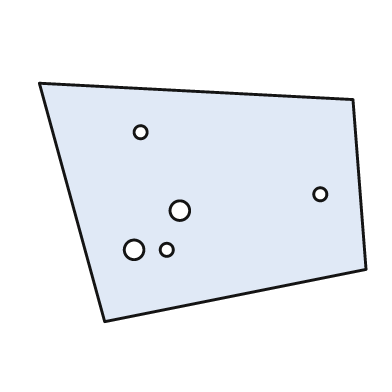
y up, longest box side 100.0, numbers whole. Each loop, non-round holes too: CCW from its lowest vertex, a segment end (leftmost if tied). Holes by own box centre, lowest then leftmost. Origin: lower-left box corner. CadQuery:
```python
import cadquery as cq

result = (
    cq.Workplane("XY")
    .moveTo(20.0, 0.0)
    .lineTo(100.0, 16.0)
    .lineTo(96.0, 68.0)
    .lineTo(0.0, 73.0)
    .close()
    .moveTo(29.0, 22.0)
    .circle(3.0)
    .moveTo(39.0, 22.0)
    .circle(2.0)
    .moveTo(43.0, 34.0)
    .circle(3.0)
    .moveTo(86.0, 39.0)
    .circle(2.0)
    .moveTo(31.0, 58.0)
    .circle(2.0)
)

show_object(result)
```